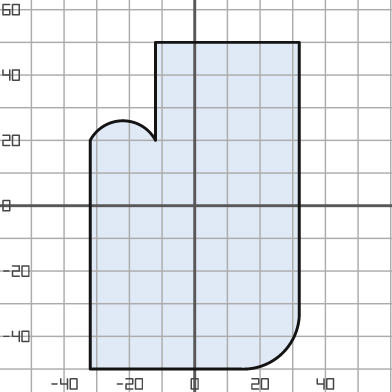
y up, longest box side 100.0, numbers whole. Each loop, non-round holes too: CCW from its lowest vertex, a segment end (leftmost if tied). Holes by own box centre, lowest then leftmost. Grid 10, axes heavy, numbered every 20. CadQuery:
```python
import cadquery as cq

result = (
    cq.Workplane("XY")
    .moveTo(-32.0, -50.0)
    .lineTo(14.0, -50.0)
    .threePointArc((27.0, -45.0), (32.0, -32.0))
    .lineTo(32.0, 50.0)
    .lineTo(-12.0, 50.0)
    .lineTo(-12.0, 20.0)
    .threePointArc((-22.0, 26.0), (-32.0, 20.0))
    .close()
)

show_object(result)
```